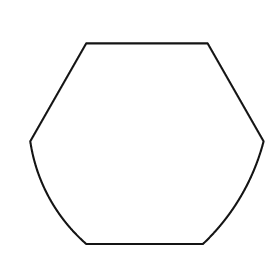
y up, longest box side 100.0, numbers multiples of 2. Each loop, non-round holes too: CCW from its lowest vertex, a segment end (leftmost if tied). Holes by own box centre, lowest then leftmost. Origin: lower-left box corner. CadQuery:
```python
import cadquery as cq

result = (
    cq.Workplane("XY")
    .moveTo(24.0, 0.0)
    .lineTo(74.0, 0.0)
    .threePointArc((90.0, 20.0), (100.0, 44.0))
    .lineTo(76.0, 86.0)
    .lineTo(24.0, 86.0)
    .lineTo(0.0, 44.0)
    .threePointArc((8.0, 20.0), (24.0, 0.0))
    .close()
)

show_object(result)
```